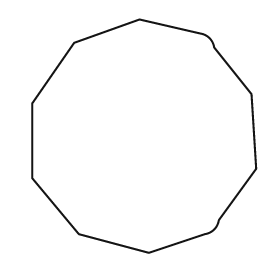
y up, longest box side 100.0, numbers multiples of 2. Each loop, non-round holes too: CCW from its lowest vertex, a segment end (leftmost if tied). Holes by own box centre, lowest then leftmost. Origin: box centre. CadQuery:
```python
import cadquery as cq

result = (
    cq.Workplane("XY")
    .moveTo(2.0, -50.0)
    .lineTo(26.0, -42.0)
    .threePointArc((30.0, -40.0), (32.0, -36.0))
    .lineTo(48.0, -14.0)
    .lineTo(46.0, 18.0)
    .lineTo(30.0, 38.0)
    .threePointArc((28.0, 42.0), (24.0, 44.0))
    .lineTo(-2.0, 50.0)
    .lineTo(-30.0, 40.0)
    .lineTo(-48.0, 14.0)
    .lineTo(-48.0, -18.0)
    .lineTo(-28.0, -42.0)
    .close()
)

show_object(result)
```